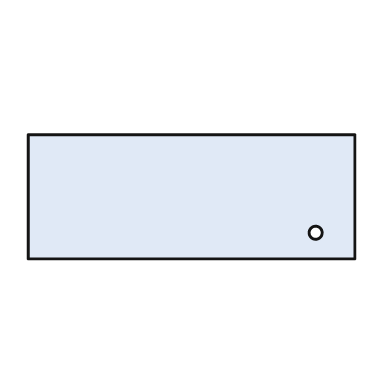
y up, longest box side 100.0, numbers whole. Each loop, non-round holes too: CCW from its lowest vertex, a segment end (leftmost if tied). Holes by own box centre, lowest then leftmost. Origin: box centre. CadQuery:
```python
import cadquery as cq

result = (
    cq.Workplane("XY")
    .moveTo(-50.0, -19.0)
    .lineTo(50.0, -19.0)
    .lineTo(50.0, 19.0)
    .lineTo(-50.0, 19.0)
    .close()
    .moveTo(38.0, -11.0)
    .circle(2.0)
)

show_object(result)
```